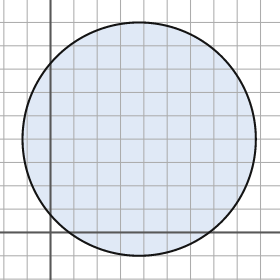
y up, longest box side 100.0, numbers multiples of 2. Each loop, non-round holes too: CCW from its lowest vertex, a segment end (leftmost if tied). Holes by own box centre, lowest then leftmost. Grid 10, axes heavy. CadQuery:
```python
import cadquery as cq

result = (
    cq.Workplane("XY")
    .moveTo(38.0, 40.0)
    .circle(50.0)
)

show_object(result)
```